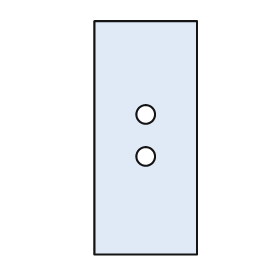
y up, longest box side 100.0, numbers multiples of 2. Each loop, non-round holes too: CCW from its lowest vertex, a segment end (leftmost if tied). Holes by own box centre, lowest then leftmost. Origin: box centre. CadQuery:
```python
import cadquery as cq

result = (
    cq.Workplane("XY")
    .moveTo(-22.0, -50.0)
    .lineTo(22.0, -50.0)
    .lineTo(22.0, 50.0)
    .lineTo(-22.0, 50.0)
    .close()
    .moveTo(0.0, -8.0)
    .circle(4.0)
    .moveTo(0.0, 10.0)
    .circle(4.0)
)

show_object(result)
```